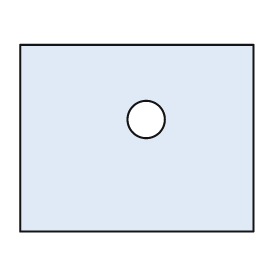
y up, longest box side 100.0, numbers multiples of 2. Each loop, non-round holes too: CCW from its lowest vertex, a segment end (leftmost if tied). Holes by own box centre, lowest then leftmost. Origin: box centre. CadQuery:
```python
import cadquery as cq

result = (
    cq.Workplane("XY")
    .moveTo(-50.0, -40.0)
    .lineTo(50.0, -40.0)
    .lineTo(50.0, 40.0)
    .lineTo(-50.0, 40.0)
    .close()
    .moveTo(4.0, 8.0)
    .circle(8.0)
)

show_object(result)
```